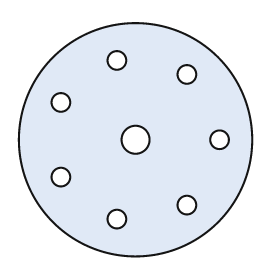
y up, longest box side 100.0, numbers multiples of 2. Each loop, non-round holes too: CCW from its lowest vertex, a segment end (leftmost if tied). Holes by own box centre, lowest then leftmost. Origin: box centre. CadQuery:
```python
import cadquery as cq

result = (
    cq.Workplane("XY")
    .moveTo(0.0, 0.0)
    .circle(50.0)
    .moveTo(-8.0, -34.0)
    .circle(4.0)
    .moveTo(22.0, -28.0)
    .circle(4.0)
    .moveTo(-32.0, -16.0)
    .circle(4.0)
    .moveTo(0.0, 0.0)
    .circle(6.0)
    .moveTo(36.0, 0.0)
    .circle(4.0)
    .moveTo(-32.0, 16.0)
    .circle(4.0)
    .moveTo(22.0, 28.0)
    .circle(4.0)
    .moveTo(-8.0, 34.0)
    .circle(4.0)
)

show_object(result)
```